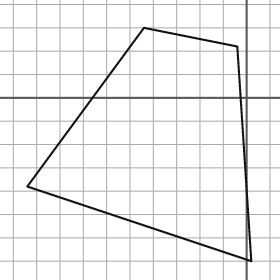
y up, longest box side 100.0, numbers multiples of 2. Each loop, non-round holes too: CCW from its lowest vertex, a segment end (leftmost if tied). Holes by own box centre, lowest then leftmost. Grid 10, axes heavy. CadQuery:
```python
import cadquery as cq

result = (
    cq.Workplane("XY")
    .moveTo(2.0, -70.0)
    .lineTo(-4.0, 22.0)
    .lineTo(-44.0, 30.0)
    .lineTo(-94.0, -38.0)
    .close()
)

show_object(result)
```